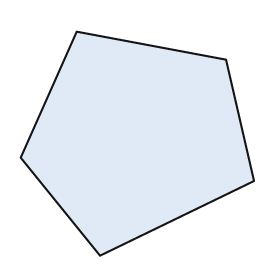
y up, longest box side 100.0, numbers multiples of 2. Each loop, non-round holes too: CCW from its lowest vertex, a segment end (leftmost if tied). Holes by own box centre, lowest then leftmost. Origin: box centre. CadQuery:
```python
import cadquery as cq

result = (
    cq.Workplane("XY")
    .moveTo(-16.0, -48.0)
    .lineTo(50.0, -16.0)
    .lineTo(38.0, 36.0)
    .lineTo(-26.0, 48.0)
    .lineTo(-50.0, -6.0)
    .close()
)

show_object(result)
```